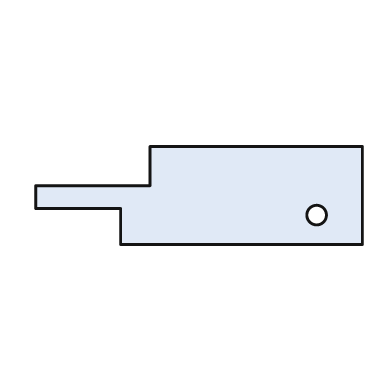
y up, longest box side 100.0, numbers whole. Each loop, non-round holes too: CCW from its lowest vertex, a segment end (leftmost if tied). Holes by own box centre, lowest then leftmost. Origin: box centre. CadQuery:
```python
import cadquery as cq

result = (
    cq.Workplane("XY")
    .moveTo(-24.0, -15.0)
    .lineTo(50.0, -15.0)
    .lineTo(50.0, 15.0)
    .lineTo(-15.0, 15.0)
    .lineTo(-15.0, 3.0)
    .lineTo(-50.0, 3.0)
    .lineTo(-50.0, -4.0)
    .lineTo(-24.0, -4.0)
    .close()
    .moveTo(36.0, -6.0)
    .circle(3.0)
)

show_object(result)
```